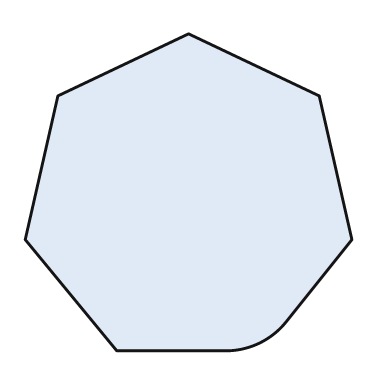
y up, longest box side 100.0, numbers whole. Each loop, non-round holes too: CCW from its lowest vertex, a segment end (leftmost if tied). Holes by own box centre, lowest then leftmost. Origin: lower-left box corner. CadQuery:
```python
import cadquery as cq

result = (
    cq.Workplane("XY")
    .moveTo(28.0, 0.0)
    .lineTo(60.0, 0.0)
    .threePointArc((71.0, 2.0), (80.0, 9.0))
    .lineTo(100.0, 34.0)
    .lineTo(90.0, 78.0)
    .lineTo(50.0, 97.0)
    .lineTo(10.0, 78.0)
    .lineTo(0.0, 34.0)
    .close()
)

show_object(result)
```